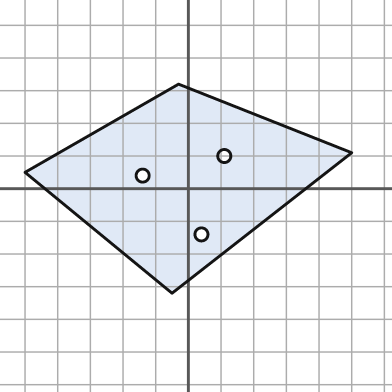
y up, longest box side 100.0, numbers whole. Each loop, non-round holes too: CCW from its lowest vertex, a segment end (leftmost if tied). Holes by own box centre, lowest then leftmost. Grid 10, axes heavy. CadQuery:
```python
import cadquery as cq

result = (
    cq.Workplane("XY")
    .moveTo(-5.0, -32.0)
    .lineTo(50.0, 11.0)
    .lineTo(-3.0, 32.0)
    .lineTo(-50.0, 5.0)
    .close()
    .moveTo(4.0, -14.0)
    .circle(2.0)
    .moveTo(-14.0, 4.0)
    .circle(2.0)
    .moveTo(11.0, 10.0)
    .circle(2.0)
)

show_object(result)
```